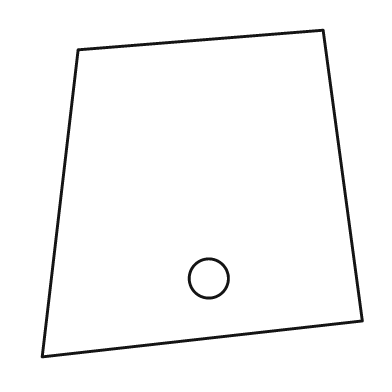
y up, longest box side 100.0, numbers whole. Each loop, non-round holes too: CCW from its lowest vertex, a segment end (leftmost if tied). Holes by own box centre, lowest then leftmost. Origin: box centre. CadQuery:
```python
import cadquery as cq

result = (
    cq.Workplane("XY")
    .moveTo(-49.0, -50.0)
    .lineTo(49.0, -39.0)
    .lineTo(37.0, 50.0)
    .lineTo(-38.0, 44.0)
    .close()
    .moveTo(2.0, -26.0)
    .circle(6.0)
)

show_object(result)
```